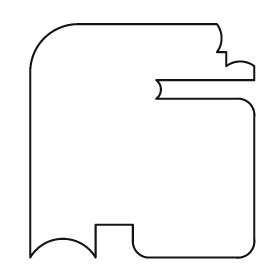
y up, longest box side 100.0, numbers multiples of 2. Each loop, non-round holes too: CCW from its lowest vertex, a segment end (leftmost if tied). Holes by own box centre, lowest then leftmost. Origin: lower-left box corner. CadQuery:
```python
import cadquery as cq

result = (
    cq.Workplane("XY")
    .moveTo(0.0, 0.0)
    .threePointArc((14.0, 8.0), (28.0, 0.0))
    .lineTo(28.0, 14.0)
    .lineTo(44.0, 14.0)
    .lineTo(44.0, 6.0)
    .threePointArc((46.0, 2.0), (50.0, 0.0))
    .lineTo(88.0, 0.0)
    .threePointArc((94.0, 2.0), (96.0, 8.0))
    .lineTo(96.0, 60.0)
    .threePointArc((94.0, 66.0), (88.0, 68.0))
    .lineTo(54.0, 68.0)
    .threePointArc((56.0, 72.0), (54.0, 76.0))
    .lineTo(96.0, 76.0)
    .lineTo(96.0, 82.0)
    .threePointArc((90.0, 84.0), (84.0, 82.0))
    .lineTo(84.0, 88.0)
    .lineTo(80.0, 88.0)
    .threePointArc((82.0, 94.0), (80.0, 100.0))
    .lineTo(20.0, 100.0)
    .threePointArc((6.0, 94.0), (0.0, 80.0))
    .close()
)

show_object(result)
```